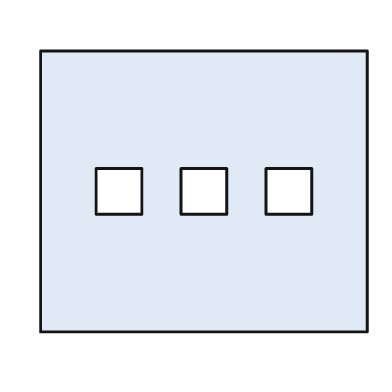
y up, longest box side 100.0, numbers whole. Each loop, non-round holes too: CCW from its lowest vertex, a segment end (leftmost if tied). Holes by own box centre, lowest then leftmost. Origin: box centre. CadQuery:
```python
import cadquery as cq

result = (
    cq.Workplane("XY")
    .moveTo(-50.0, -43.0)
    .lineTo(50.0, -43.0)
    .lineTo(50.0, 43.0)
    .lineTo(-50.0, 43.0)
    .close()
    .moveTo(-33.0, -7.0)
    .lineTo(-19.0, -7.0)
    .lineTo(-19.0, 7.0)
    .lineTo(-33.0, 7.0)
    .close()
    .moveTo(-7.0, -7.0)
    .lineTo(7.0, -7.0)
    .lineTo(7.0, 7.0)
    .lineTo(-7.0, 7.0)
    .close()
    .moveTo(19.0, -7.0)
    .lineTo(33.0, -7.0)
    .lineTo(33.0, 7.0)
    .lineTo(19.0, 7.0)
    .close()
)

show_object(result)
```